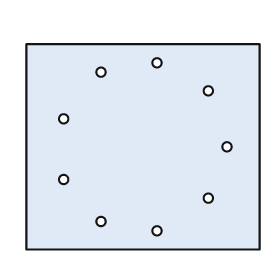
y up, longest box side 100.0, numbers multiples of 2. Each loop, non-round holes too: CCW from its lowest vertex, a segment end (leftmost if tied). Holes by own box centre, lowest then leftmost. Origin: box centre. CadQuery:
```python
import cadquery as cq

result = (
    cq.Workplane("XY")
    .moveTo(-50.0, -44.0)
    .lineTo(50.0, -44.0)
    .lineTo(50.0, 44.0)
    .lineTo(-50.0, 44.0)
    .close()
    .moveTo(6.0, -36.0)
    .circle(2.0)
    .moveTo(-18.0, -32.0)
    .circle(2.0)
    .moveTo(28.0, -22.0)
    .circle(2.0)
    .moveTo(-34.0, -14.0)
    .circle(2.0)
    .moveTo(36.0, 0.0)
    .circle(2.0)
    .moveTo(-34.0, 12.0)
    .circle(2.0)
    .moveTo(28.0, 24.0)
    .circle(2.0)
    .moveTo(-18.0, 32.0)
    .circle(2.0)
    .moveTo(6.0, 36.0)
    .circle(2.0)
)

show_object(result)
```